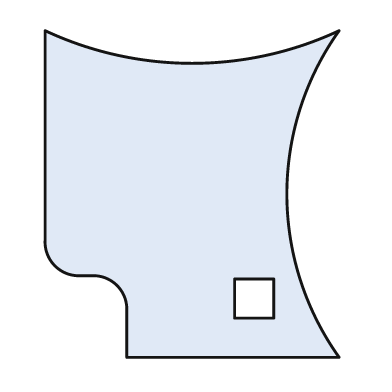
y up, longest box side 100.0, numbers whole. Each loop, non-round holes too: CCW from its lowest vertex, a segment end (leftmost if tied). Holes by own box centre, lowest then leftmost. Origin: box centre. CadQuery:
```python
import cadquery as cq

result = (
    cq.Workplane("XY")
    .moveTo(-20.0, -50.0)
    .lineTo(45.0, -50.0)
    .threePointArc((29.0, 0.0), (45.0, 50.0))
    .threePointArc((0.0, 40.0), (-45.0, 50.0))
    .lineTo(-45.0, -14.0)
    .threePointArc((-42.0, -22.0), (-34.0, -25.0))
    .lineTo(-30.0, -25.0)
    .threePointArc((-23.0, -28.0), (-20.0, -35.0))
    .close()
    .moveTo(13.0, -38.0)
    .lineTo(25.0, -38.0)
    .lineTo(25.0, -26.0)
    .lineTo(13.0, -26.0)
    .close()
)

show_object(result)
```